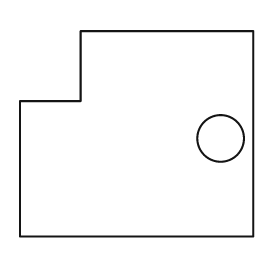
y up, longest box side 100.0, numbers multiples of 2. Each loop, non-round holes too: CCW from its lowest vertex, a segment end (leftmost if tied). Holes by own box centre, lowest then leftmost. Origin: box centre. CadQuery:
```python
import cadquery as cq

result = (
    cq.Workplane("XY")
    .moveTo(-50.0, -44.0)
    .lineTo(50.0, -44.0)
    .lineTo(50.0, 44.0)
    .lineTo(-24.0, 44.0)
    .lineTo(-24.0, 14.0)
    .lineTo(-50.0, 14.0)
    .close()
    .moveTo(36.0, -2.0)
    .circle(10.0)
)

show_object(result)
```